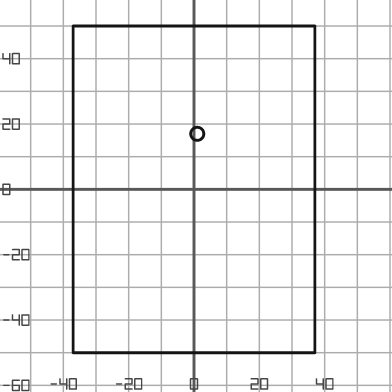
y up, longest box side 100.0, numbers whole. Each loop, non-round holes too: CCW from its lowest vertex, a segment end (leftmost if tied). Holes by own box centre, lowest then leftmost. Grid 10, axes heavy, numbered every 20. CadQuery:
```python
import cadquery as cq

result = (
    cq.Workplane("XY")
    .moveTo(-37.0, -50.0)
    .lineTo(37.0, -50.0)
    .lineTo(37.0, 50.0)
    .lineTo(-37.0, 50.0)
    .close()
    .moveTo(1.0, 17.0)
    .circle(2.0)
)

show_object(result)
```